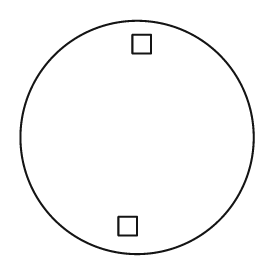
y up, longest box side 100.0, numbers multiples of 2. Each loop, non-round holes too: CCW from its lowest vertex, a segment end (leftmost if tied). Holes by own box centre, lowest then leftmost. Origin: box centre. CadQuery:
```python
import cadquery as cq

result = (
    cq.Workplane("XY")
    .moveTo(0.0, 0.0)
    .circle(50.0)
    .moveTo(-8.0, -42.0)
    .lineTo(0.0, -42.0)
    .lineTo(0.0, -34.0)
    .lineTo(-8.0, -34.0)
    .close()
    .moveTo(-2.0, 36.0)
    .lineTo(6.0, 36.0)
    .lineTo(6.0, 44.0)
    .lineTo(-2.0, 44.0)
    .close()
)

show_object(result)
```